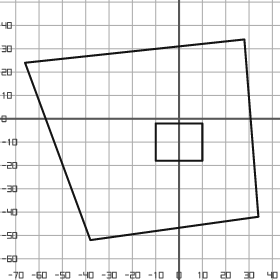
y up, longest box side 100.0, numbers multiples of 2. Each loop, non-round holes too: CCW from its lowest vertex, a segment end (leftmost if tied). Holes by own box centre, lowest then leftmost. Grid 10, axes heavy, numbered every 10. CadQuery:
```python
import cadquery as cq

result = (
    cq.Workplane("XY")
    .moveTo(-38.0, -52.0)
    .lineTo(34.0, -42.0)
    .lineTo(28.0, 34.0)
    .lineTo(-66.0, 24.0)
    .close()
    .moveTo(-10.0, -18.0)
    .lineTo(10.0, -18.0)
    .lineTo(10.0, -2.0)
    .lineTo(-10.0, -2.0)
    .close()
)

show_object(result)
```